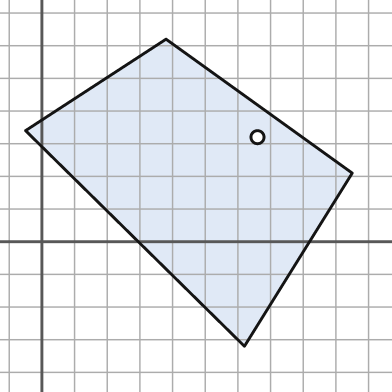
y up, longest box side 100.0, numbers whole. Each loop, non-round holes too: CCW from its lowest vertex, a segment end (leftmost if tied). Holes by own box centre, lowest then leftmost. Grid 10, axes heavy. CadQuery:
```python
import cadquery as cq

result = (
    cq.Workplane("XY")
    .moveTo(62.0, -32.0)
    .lineTo(95.0, 21.0)
    .lineTo(38.0, 62.0)
    .lineTo(-5.0, 34.0)
    .close()
    .moveTo(66.0, 32.0)
    .circle(2.0)
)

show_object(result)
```